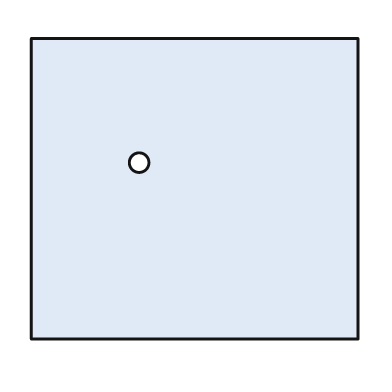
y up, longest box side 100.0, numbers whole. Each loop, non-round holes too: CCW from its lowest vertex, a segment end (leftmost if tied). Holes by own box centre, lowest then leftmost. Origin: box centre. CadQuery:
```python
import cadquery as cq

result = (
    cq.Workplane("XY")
    .moveTo(-50.0, -46.0)
    .lineTo(50.0, -46.0)
    .lineTo(50.0, 46.0)
    .lineTo(-50.0, 46.0)
    .close()
    .moveTo(-17.0, 8.0)
    .circle(3.0)
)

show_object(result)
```